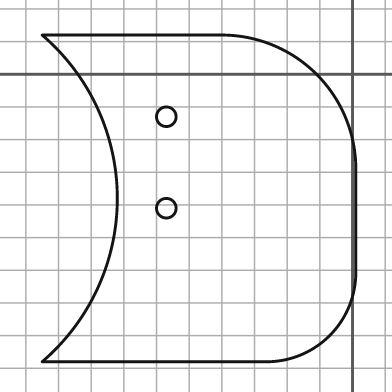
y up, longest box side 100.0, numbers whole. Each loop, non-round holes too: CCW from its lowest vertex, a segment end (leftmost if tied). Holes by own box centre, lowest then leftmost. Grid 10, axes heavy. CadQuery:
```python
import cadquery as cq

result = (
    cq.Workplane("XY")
    .moveTo(-95.0, -88.0)
    .lineTo(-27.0, -88.0)
    .threePointArc((-7.0, -80.0), (1.0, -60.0))
    .lineTo(1.0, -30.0)
    .threePointArc((-11.0, 0.0), (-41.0, 12.0))
    .lineTo(-95.0, 12.0)
    .threePointArc((-72.0, -38.0), (-95.0, -88.0))
    .close()
    .moveTo(-57.0, -41.0)
    .circle(3.0)
    .moveTo(-57.0, -13.0)
    .circle(3.0)
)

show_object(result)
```